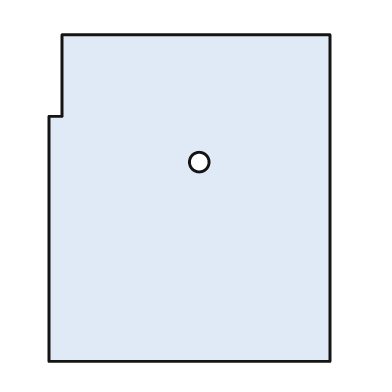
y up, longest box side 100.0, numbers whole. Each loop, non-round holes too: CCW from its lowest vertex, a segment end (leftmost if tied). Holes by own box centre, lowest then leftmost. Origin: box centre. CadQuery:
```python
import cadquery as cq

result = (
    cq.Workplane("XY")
    .moveTo(-43.0, -50.0)
    .lineTo(43.0, -50.0)
    .lineTo(43.0, 50.0)
    .lineTo(-39.0, 50.0)
    .lineTo(-39.0, 25.0)
    .lineTo(-43.0, 25.0)
    .close()
    .moveTo(3.0, 11.0)
    .circle(3.0)
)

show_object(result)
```